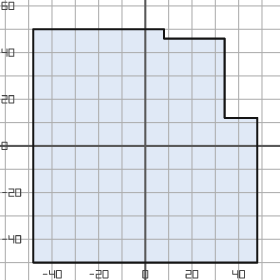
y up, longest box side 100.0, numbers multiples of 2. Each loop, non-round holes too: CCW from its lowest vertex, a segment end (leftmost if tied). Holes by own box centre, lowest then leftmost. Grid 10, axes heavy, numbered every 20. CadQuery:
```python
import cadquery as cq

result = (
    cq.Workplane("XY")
    .moveTo(-48.0, -50.0)
    .lineTo(48.0, -50.0)
    .lineTo(48.0, 12.0)
    .lineTo(34.0, 12.0)
    .lineTo(34.0, 46.0)
    .lineTo(8.0, 46.0)
    .lineTo(8.0, 50.0)
    .lineTo(-48.0, 50.0)
    .close()
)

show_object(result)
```